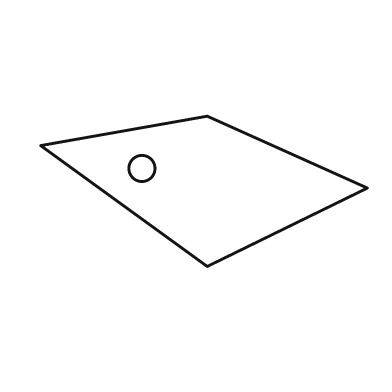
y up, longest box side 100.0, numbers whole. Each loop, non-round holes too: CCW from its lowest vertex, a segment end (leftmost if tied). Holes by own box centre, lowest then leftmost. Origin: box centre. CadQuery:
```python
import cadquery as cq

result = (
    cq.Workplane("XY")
    .moveTo(1.0, -23.0)
    .lineTo(50.0, 1.0)
    .lineTo(1.0, 23.0)
    .lineTo(-50.0, 14.0)
    .close()
    .moveTo(-19.0, 7.0)
    .circle(4.0)
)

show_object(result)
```